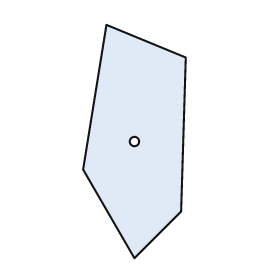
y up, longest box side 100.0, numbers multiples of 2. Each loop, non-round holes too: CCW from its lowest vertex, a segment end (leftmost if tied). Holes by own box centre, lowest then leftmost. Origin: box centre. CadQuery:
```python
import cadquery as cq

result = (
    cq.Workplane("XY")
    .moveTo(0.0, -50.0)
    .lineTo(20.0, -30.0)
    .lineTo(22.0, 36.0)
    .lineTo(-12.0, 50.0)
    .lineTo(-22.0, -12.0)
    .close()
    .moveTo(0.0, 0.0)
    .circle(2.0)
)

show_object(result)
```